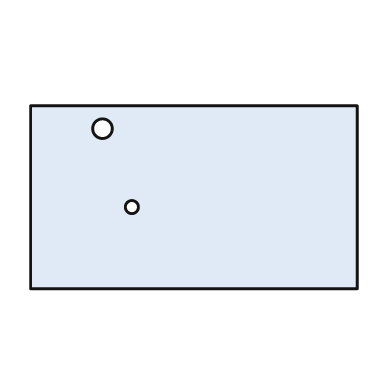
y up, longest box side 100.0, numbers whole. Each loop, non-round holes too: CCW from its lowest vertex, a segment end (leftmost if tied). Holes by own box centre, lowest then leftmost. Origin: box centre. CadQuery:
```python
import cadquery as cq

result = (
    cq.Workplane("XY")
    .moveTo(-50.0, -28.0)
    .lineTo(50.0, -28.0)
    .lineTo(50.0, 28.0)
    .lineTo(-50.0, 28.0)
    .close()
    .moveTo(-19.0, -3.0)
    .circle(2.0)
    .moveTo(-28.0, 21.0)
    .circle(3.0)
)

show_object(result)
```